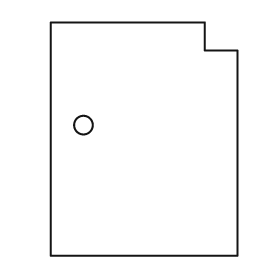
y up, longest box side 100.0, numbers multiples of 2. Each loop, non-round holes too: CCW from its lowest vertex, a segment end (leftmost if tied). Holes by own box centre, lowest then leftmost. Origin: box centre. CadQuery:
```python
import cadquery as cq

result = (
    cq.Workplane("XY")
    .moveTo(-40.0, -50.0)
    .lineTo(40.0, -50.0)
    .lineTo(40.0, 38.0)
    .lineTo(26.0, 38.0)
    .lineTo(26.0, 50.0)
    .lineTo(-40.0, 50.0)
    .close()
    .moveTo(-26.0, 6.0)
    .circle(4.0)
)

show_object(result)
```